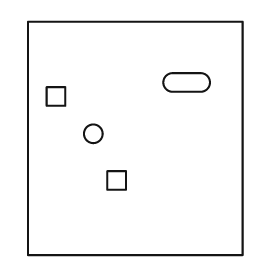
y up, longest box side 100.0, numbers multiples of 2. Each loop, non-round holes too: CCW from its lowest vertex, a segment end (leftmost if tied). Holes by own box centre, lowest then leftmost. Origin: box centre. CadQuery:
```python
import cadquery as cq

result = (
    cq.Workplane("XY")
    .moveTo(-46.0, -50.0)
    .lineTo(46.0, -50.0)
    .lineTo(46.0, 50.0)
    .lineTo(-46.0, 50.0)
    .close()
    .moveTo(-12.0, -22.0)
    .lineTo(-4.0, -22.0)
    .lineTo(-4.0, -14.0)
    .lineTo(-12.0, -14.0)
    .close()
    .moveTo(-18.0, 2.0)
    .circle(4.0)
    .moveTo(-38.0, 14.0)
    .lineTo(-30.0, 14.0)
    .lineTo(-30.0, 22.0)
    .lineTo(-38.0, 22.0)
    .close()
    .moveTo(16.0, 20.0)
    .lineTo(28.0, 20.0)
    .threePointArc((32.0, 24.0), (28.0, 28.0))
    .lineTo(16.0, 28.0)
    .threePointArc((12.0, 24.0), (16.0, 20.0))
    .close()
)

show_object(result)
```